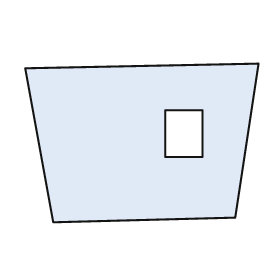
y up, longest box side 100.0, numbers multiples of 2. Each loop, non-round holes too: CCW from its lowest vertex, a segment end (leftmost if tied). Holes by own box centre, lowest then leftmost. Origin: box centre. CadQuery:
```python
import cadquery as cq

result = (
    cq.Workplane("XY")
    .moveTo(-38.0, -34.0)
    .lineTo(40.0, -32.0)
    .lineTo(50.0, 34.0)
    .lineTo(-50.0, 32.0)
    .close()
    .moveTo(10.0, -6.0)
    .lineTo(26.0, -6.0)
    .lineTo(26.0, 14.0)
    .lineTo(10.0, 14.0)
    .close()
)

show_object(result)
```